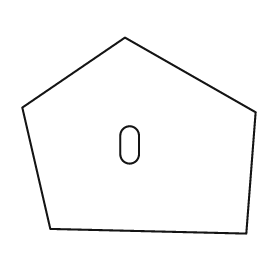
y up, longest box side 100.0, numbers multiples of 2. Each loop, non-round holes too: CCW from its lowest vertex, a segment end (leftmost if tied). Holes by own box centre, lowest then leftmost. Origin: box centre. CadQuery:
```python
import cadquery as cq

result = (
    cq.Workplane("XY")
    .moveTo(46.0, -42.0)
    .lineTo(50.0, 10.0)
    .lineTo(-6.0, 42.0)
    .lineTo(-50.0, 12.0)
    .lineTo(-38.0, -40.0)
    .close()
    .moveTo(-8.0, -8.0)
    .threePointArc((-4.0, -12.0), (0.0, -8.0))
    .lineTo(0.0, 0.0)
    .threePointArc((-4.0, 4.0), (-8.0, 0.0))
    .close()
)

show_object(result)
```